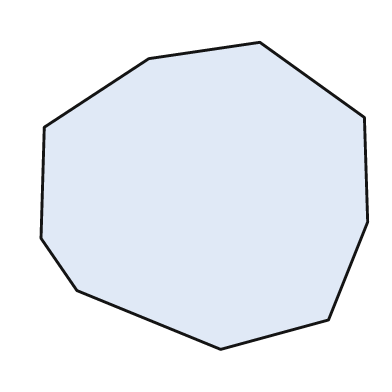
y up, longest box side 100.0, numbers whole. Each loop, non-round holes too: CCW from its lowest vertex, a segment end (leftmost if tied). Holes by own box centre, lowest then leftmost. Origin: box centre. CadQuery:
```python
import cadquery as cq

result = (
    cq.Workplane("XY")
    .moveTo(5.0, -47.0)
    .lineTo(38.0, -38.0)
    .lineTo(50.0, -8.0)
    .lineTo(49.0, 24.0)
    .lineTo(17.0, 47.0)
    .lineTo(-17.0, 42.0)
    .lineTo(-49.0, 21.0)
    .lineTo(-50.0, -13.0)
    .lineTo(-39.0, -29.0)
    .close()
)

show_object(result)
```